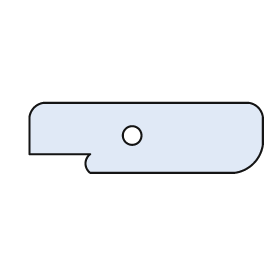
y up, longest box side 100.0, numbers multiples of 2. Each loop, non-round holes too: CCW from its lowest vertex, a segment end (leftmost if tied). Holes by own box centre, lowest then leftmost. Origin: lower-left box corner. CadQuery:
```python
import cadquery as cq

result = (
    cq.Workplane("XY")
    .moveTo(26.0, 0.0)
    .lineTo(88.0, 0.0)
    .threePointArc((96.0, 4.0), (100.0, 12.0))
    .lineTo(100.0, 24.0)
    .threePointArc((98.0, 28.0), (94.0, 30.0))
    .lineTo(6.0, 30.0)
    .threePointArc((2.0, 28.0), (0.0, 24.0))
    .lineTo(0.0, 8.0)
    .lineTo(26.0, 8.0)
    .threePointArc((24.0, 4.0), (26.0, 0.0))
    .close()
    .moveTo(44.0, 16.0)
    .circle(4.0)
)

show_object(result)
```